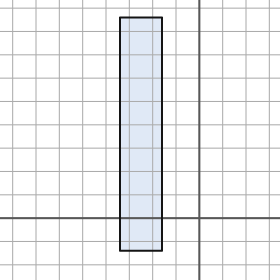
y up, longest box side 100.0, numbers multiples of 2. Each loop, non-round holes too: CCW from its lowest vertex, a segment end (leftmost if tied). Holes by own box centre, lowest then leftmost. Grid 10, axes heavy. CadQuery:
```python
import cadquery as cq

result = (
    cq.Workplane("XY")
    .moveTo(-34.0, -14.0)
    .lineTo(-16.0, -14.0)
    .lineTo(-16.0, 86.0)
    .lineTo(-34.0, 86.0)
    .close()
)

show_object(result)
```